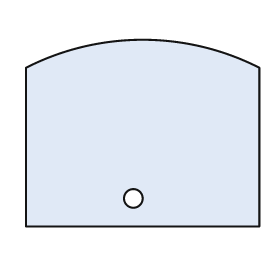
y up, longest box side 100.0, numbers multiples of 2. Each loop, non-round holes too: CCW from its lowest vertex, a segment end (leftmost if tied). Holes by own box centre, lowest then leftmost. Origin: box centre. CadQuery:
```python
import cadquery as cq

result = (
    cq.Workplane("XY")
    .moveTo(-50.0, -40.0)
    .lineTo(50.0, -40.0)
    .lineTo(50.0, 28.0)
    .threePointArc((0.0, 40.0), (-50.0, 28.0))
    .close()
    .moveTo(-4.0, -28.0)
    .circle(4.0)
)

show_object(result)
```